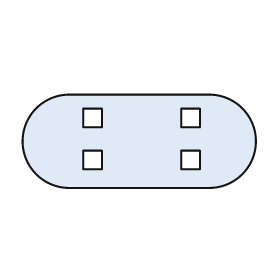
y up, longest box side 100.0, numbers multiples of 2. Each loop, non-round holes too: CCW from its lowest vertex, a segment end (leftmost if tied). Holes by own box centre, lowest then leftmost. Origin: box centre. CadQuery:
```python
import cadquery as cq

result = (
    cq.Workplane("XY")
    .moveTo(-30.0, -20.0)
    .lineTo(30.0, -20.0)
    .threePointArc((50.0, 0.0), (30.0, 20.0))
    .lineTo(-30.0, 20.0)
    .threePointArc((-50.0, 0.0), (-30.0, -20.0))
    .close()
    .moveTo(-24.0, -12.0)
    .lineTo(-16.0, -12.0)
    .lineTo(-16.0, -4.0)
    .lineTo(-24.0, -4.0)
    .close()
    .moveTo(18.0, -12.0)
    .lineTo(26.0, -12.0)
    .lineTo(26.0, -4.0)
    .lineTo(18.0, -4.0)
    .close()
    .moveTo(-24.0, 6.0)
    .lineTo(-16.0, 6.0)
    .lineTo(-16.0, 14.0)
    .lineTo(-24.0, 14.0)
    .close()
    .moveTo(18.0, 6.0)
    .lineTo(26.0, 6.0)
    .lineTo(26.0, 14.0)
    .lineTo(18.0, 14.0)
    .close()
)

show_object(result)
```